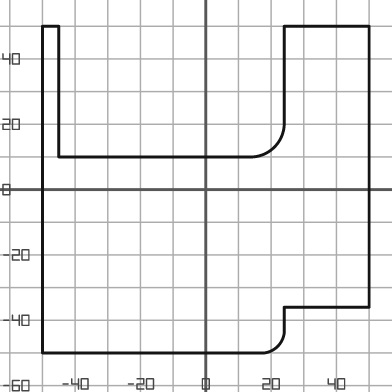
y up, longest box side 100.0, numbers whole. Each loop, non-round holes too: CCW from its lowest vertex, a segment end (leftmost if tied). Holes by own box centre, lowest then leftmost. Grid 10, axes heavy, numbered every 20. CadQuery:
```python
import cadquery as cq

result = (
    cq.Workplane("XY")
    .moveTo(-50.0, -50.0)
    .lineTo(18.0, -50.0)
    .threePointArc((22.0, -48.0), (24.0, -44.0))
    .lineTo(24.0, -36.0)
    .lineTo(50.0, -36.0)
    .lineTo(50.0, 50.0)
    .lineTo(24.0, 50.0)
    .lineTo(24.0, 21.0)
    .threePointArc((21.0, 13.0), (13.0, 10.0))
    .lineTo(-45.0, 10.0)
    .lineTo(-45.0, 50.0)
    .lineTo(-50.0, 50.0)
    .close()
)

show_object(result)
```